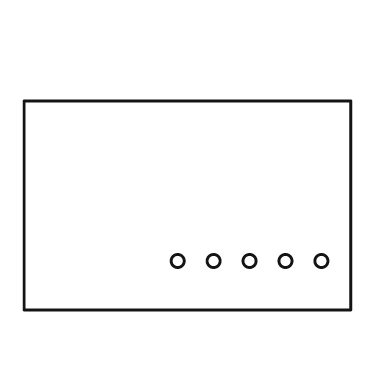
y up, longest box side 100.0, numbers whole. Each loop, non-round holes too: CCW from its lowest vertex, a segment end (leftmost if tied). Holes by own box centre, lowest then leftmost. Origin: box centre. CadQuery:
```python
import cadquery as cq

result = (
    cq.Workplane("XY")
    .moveTo(-50.0, -32.0)
    .lineTo(50.0, -32.0)
    .lineTo(50.0, 32.0)
    .lineTo(-50.0, 32.0)
    .close()
    .moveTo(-3.0, -17.0)
    .circle(2.0)
    .moveTo(8.0, -17.0)
    .circle(2.0)
    .moveTo(19.0, -17.0)
    .circle(2.0)
    .moveTo(30.0, -17.0)
    .circle(2.0)
    .moveTo(41.0, -17.0)
    .circle(2.0)
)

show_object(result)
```